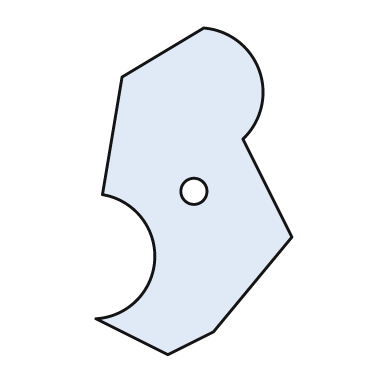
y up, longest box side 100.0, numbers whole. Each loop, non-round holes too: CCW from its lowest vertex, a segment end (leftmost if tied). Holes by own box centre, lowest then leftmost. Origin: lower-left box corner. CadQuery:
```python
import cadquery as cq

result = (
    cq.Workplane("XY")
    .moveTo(22.0, 0.0)
    .lineTo(36.0, 7.0)
    .lineTo(60.0, 36.0)
    .lineTo(45.0, 66.0)
    .threePointArc((50.0, 87.0), (33.0, 100.0))
    .lineTo(8.0, 85.0)
    .lineTo(2.0, 49.0)
    .threePointArc((18.0, 29.0), (0.0, 11.0))
    .close()
    .moveTo(30.0, 50.0)
    .circle(4.0)
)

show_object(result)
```